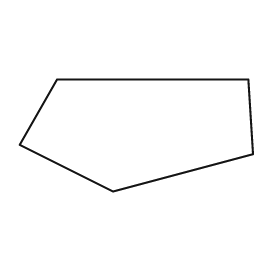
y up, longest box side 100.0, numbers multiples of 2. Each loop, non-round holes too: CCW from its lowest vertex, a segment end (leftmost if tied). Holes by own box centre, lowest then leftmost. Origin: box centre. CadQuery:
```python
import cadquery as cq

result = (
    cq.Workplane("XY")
    .moveTo(-10.0, -24.0)
    .lineTo(50.0, -8.0)
    .lineTo(48.0, 24.0)
    .lineTo(-34.0, 24.0)
    .lineTo(-50.0, -4.0)
    .close()
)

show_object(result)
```